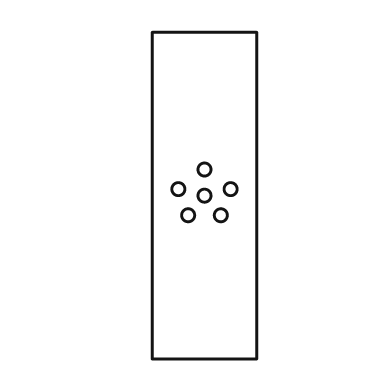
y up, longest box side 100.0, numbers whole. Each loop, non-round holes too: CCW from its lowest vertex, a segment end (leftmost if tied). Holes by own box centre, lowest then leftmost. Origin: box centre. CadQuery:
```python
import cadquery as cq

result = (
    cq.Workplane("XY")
    .moveTo(-16.0, -50.0)
    .lineTo(16.0, -50.0)
    .lineTo(16.0, 50.0)
    .lineTo(-16.0, 50.0)
    .close()
    .moveTo(-5.0, -6.0)
    .circle(2.0)
    .moveTo(5.0, -6.0)
    .circle(2.0)
    .moveTo(0.0, 0.0)
    .circle(2.0)
    .moveTo(-8.0, 2.0)
    .circle(2.0)
    .moveTo(8.0, 2.0)
    .circle(2.0)
    .moveTo(0.0, 8.0)
    .circle(2.0)
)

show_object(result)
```